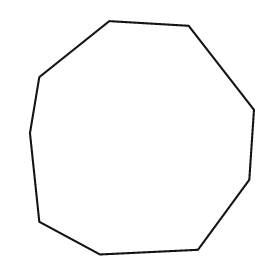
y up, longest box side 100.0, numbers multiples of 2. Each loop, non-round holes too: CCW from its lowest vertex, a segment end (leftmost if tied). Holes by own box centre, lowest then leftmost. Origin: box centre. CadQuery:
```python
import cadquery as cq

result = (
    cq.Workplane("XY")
    .moveTo(-18.0, -50.0)
    .lineTo(24.0, -48.0)
    .lineTo(46.0, -18.0)
    .lineTo(48.0, 12.0)
    .lineTo(20.0, 48.0)
    .lineTo(-14.0, 50.0)
    .lineTo(-44.0, 26.0)
    .lineTo(-48.0, 2.0)
    .lineTo(-44.0, -36.0)
    .close()
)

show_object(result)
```